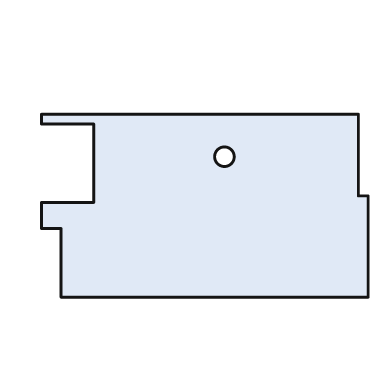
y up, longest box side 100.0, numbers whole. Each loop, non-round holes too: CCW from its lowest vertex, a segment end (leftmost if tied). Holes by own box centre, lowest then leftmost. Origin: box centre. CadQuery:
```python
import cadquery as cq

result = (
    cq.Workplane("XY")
    .moveTo(-44.0, -28.0)
    .lineTo(50.0, -28.0)
    .lineTo(50.0, 3.0)
    .lineTo(47.0, 3.0)
    .lineTo(47.0, 28.0)
    .lineTo(-50.0, 28.0)
    .lineTo(-50.0, 25.0)
    .lineTo(-34.0, 25.0)
    .lineTo(-34.0, 1.0)
    .lineTo(-50.0, 1.0)
    .lineTo(-50.0, -7.0)
    .lineTo(-44.0, -7.0)
    .close()
    .moveTo(6.0, 15.0)
    .circle(3.0)
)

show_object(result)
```